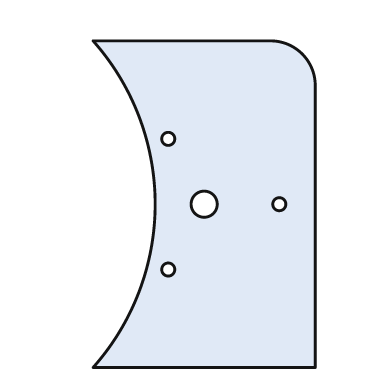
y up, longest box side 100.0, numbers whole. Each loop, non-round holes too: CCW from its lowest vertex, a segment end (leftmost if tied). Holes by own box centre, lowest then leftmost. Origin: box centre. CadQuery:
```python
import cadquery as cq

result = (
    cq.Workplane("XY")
    .moveTo(-34.0, -50.0)
    .lineTo(34.0, -50.0)
    .lineTo(34.0, 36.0)
    .threePointArc((30.0, 46.0), (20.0, 50.0))
    .lineTo(-34.0, 50.0)
    .threePointArc((-15.0, 0.0), (-34.0, -50.0))
    .close()
    .moveTo(-11.0, -20.0)
    .circle(2.0)
    .moveTo(0.0, 0.0)
    .circle(4.0)
    .moveTo(23.0, 0.0)
    .circle(2.0)
    .moveTo(-11.0, 20.0)
    .circle(2.0)
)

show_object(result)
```